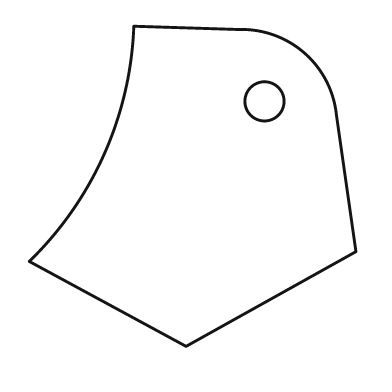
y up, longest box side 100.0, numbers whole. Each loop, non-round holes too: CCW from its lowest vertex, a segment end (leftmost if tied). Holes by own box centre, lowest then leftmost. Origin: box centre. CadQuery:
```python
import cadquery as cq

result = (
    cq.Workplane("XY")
    .moveTo(-2.0, -49.0)
    .lineTo(50.0, -20.0)
    .lineTo(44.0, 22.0)
    .threePointArc((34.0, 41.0), (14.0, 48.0))
    .lineTo(-18.0, 49.0)
    .threePointArc((-27.0, 10.0), (-50.0, -23.0))
    .close()
    .moveTo(22.0, 26.0)
    .circle(6.0)
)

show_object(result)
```